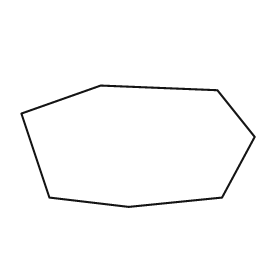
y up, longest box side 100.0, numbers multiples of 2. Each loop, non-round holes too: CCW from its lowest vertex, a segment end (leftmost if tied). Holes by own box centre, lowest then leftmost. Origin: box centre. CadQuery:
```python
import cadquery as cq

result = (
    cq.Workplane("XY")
    .moveTo(-4.0, -26.0)
    .lineTo(36.0, -22.0)
    .lineTo(50.0, 4.0)
    .lineTo(34.0, 24.0)
    .lineTo(-16.0, 26.0)
    .lineTo(-50.0, 14.0)
    .lineTo(-38.0, -22.0)
    .close()
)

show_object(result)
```